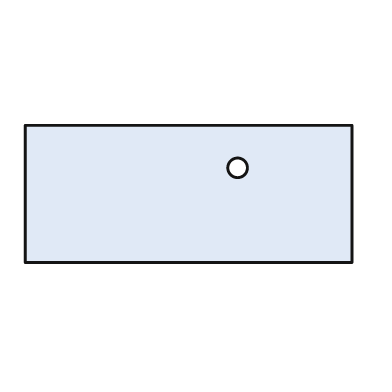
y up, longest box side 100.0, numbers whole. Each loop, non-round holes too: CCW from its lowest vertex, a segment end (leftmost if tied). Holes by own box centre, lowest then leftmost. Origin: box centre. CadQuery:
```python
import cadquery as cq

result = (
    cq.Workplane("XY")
    .moveTo(-50.0, -21.0)
    .lineTo(50.0, -21.0)
    .lineTo(50.0, 21.0)
    .lineTo(-50.0, 21.0)
    .close()
    .moveTo(15.0, 8.0)
    .circle(3.0)
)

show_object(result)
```